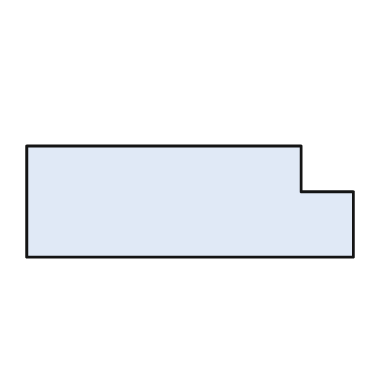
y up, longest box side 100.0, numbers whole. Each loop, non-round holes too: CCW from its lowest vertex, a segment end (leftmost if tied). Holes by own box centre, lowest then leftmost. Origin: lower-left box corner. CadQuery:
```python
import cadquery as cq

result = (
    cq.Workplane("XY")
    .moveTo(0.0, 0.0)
    .lineTo(100.0, 0.0)
    .lineTo(100.0, 20.0)
    .lineTo(84.0, 20.0)
    .lineTo(84.0, 34.0)
    .lineTo(0.0, 34.0)
    .close()
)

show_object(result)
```